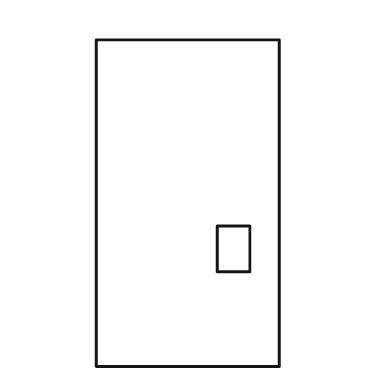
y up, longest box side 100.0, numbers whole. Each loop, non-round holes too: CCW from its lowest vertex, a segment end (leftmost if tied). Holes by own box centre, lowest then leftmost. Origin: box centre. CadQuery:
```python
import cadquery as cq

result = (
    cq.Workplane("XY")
    .moveTo(-28.0, -50.0)
    .lineTo(28.0, -50.0)
    .lineTo(28.0, 50.0)
    .lineTo(-28.0, 50.0)
    .close()
    .moveTo(9.0, -21.0)
    .lineTo(19.0, -21.0)
    .lineTo(19.0, -7.0)
    .lineTo(9.0, -7.0)
    .close()
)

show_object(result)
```